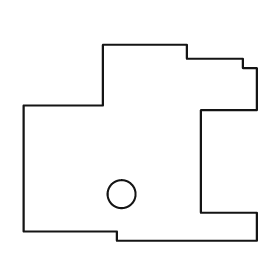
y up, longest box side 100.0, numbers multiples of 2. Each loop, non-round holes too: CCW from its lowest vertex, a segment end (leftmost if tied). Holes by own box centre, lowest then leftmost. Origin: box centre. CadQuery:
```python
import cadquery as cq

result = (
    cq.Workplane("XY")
    .moveTo(-10.0, -42.0)
    .lineTo(50.0, -42.0)
    .lineTo(50.0, -30.0)
    .lineTo(26.0, -30.0)
    .lineTo(26.0, 14.0)
    .lineTo(50.0, 14.0)
    .lineTo(50.0, 32.0)
    .lineTo(44.0, 32.0)
    .lineTo(44.0, 36.0)
    .lineTo(20.0, 36.0)
    .lineTo(20.0, 42.0)
    .lineTo(-16.0, 42.0)
    .lineTo(-16.0, 16.0)
    .lineTo(-50.0, 16.0)
    .lineTo(-50.0, -38.0)
    .lineTo(-10.0, -38.0)
    .close()
    .moveTo(-8.0, -22.0)
    .circle(6.0)
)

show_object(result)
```